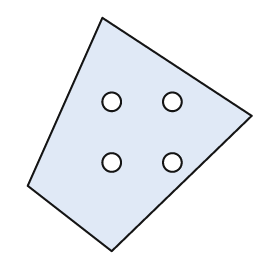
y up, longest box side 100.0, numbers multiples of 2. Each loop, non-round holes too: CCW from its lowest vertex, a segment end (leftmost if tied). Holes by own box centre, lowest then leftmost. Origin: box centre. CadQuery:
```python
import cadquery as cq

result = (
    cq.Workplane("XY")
    .moveTo(-12.0, -50.0)
    .lineTo(48.0, 8.0)
    .lineTo(-16.0, 50.0)
    .lineTo(-48.0, -22.0)
    .close()
    .moveTo(-12.0, -12.0)
    .circle(4.0)
    .moveTo(14.0, -12.0)
    .circle(4.0)
    .moveTo(-12.0, 14.0)
    .circle(4.0)
    .moveTo(14.0, 14.0)
    .circle(4.0)
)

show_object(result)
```